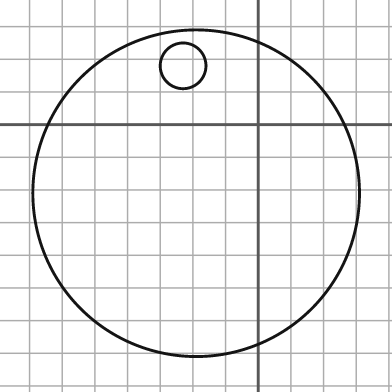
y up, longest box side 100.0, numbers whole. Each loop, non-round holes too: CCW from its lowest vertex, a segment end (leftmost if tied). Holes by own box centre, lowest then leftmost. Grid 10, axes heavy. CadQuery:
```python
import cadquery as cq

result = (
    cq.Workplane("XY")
    .moveTo(-19.0, -21.0)
    .circle(50.0)
    .moveTo(-23.0, 18.0)
    .circle(7.0)
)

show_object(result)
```